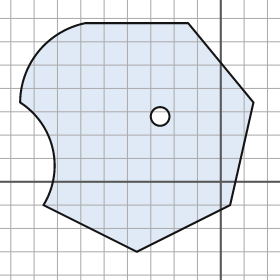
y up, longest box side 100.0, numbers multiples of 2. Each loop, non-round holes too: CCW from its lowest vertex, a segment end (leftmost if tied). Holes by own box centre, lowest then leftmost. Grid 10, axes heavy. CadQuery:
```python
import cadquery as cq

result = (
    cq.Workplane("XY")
    .moveTo(-36.0, -30.0)
    .lineTo(4.0, -10.0)
    .lineTo(14.0, 34.0)
    .lineTo(-14.0, 68.0)
    .lineTo(-58.0, 68.0)
    .threePointArc((-78.0, 56.0), (-86.0, 34.0))
    .threePointArc((-72.0, 14.0), (-76.0, -10.0))
    .close()
    .moveTo(-26.0, 28.0)
    .circle(4.0)
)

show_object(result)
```